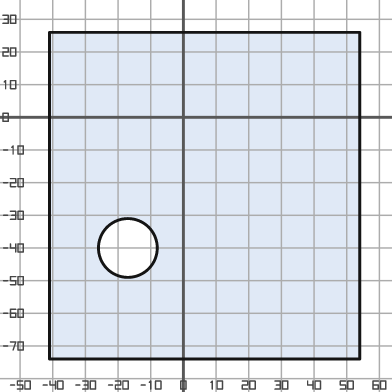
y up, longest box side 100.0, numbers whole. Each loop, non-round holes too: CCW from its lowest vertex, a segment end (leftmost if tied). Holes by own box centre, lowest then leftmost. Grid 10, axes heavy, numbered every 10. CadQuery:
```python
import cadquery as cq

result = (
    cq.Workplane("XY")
    .moveTo(-41.0, -74.0)
    .lineTo(54.0, -74.0)
    .lineTo(54.0, 26.0)
    .lineTo(-41.0, 26.0)
    .close()
    .moveTo(-17.0, -40.0)
    .circle(9.0)
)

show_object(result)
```